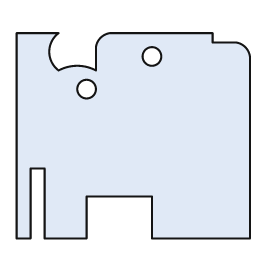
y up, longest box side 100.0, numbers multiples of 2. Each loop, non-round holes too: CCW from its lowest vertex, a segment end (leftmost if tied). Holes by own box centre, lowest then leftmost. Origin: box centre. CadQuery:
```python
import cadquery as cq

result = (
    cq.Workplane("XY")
    .moveTo(-50.0, -44.0)
    .lineTo(-44.0, -44.0)
    .lineTo(-44.0, -14.0)
    .lineTo(-38.0, -14.0)
    .lineTo(-38.0, -44.0)
    .lineTo(-20.0, -44.0)
    .lineTo(-20.0, -26.0)
    .lineTo(8.0, -26.0)
    .lineTo(8.0, -44.0)
    .lineTo(50.0, -44.0)
    .lineTo(50.0, 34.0)
    .threePointArc((48.0, 38.0), (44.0, 40.0))
    .lineTo(34.0, 40.0)
    .lineTo(34.0, 44.0)
    .lineTo(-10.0, 44.0)
    .threePointArc((-14.0, 42.0), (-16.0, 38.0))
    .lineTo(-16.0, 28.0)
    .threePointArc((-24.0, 30.0), (-32.0, 28.0))
    .threePointArc((-36.0, 36.0), (-32.0, 44.0))
    .lineTo(-50.0, 44.0)
    .close()
    .moveTo(-20.0, 20.0)
    .circle(4.0)
    .moveTo(8.0, 34.0)
    .circle(4.0)
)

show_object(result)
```